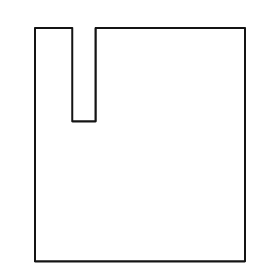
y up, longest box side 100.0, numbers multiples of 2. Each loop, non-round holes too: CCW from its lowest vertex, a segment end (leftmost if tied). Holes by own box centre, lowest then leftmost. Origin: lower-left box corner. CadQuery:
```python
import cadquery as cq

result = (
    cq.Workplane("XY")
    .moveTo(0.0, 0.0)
    .lineTo(90.0, 0.0)
    .lineTo(90.0, 100.0)
    .lineTo(26.0, 100.0)
    .lineTo(26.0, 60.0)
    .lineTo(16.0, 60.0)
    .lineTo(16.0, 100.0)
    .lineTo(0.0, 100.0)
    .close()
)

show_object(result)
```